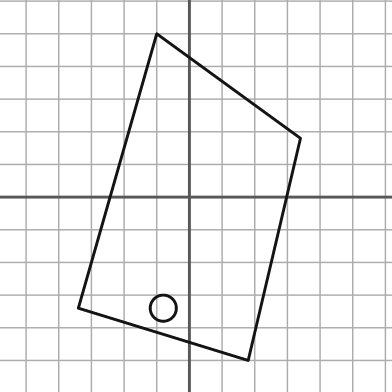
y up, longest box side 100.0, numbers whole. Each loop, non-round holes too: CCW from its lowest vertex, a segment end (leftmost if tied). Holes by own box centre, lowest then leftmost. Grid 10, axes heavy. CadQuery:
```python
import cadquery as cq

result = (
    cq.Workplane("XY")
    .moveTo(18.0, -50.0)
    .lineTo(34.0, 18.0)
    .lineTo(-10.0, 50.0)
    .lineTo(-34.0, -34.0)
    .close()
    .moveTo(-8.0, -34.0)
    .circle(4.0)
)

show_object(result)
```